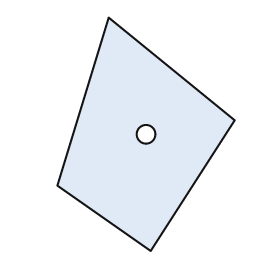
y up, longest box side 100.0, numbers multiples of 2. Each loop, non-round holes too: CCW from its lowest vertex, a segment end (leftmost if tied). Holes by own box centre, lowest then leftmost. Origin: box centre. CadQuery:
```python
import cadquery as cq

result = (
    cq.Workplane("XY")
    .moveTo(2.0, -50.0)
    .lineTo(38.0, 6.0)
    .lineTo(-16.0, 50.0)
    .lineTo(-38.0, -22.0)
    .close()
    .moveTo(0.0, 0.0)
    .circle(4.0)
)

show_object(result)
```